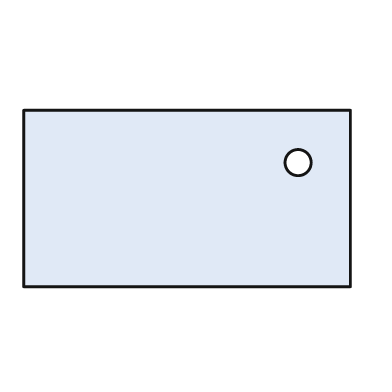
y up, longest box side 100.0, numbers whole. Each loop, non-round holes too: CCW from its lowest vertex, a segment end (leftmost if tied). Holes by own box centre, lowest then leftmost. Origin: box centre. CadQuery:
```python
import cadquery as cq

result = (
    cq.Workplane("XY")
    .moveTo(-50.0, -27.0)
    .lineTo(50.0, -27.0)
    .lineTo(50.0, 27.0)
    .lineTo(-50.0, 27.0)
    .close()
    .moveTo(34.0, 11.0)
    .circle(4.0)
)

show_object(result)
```